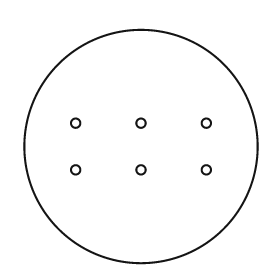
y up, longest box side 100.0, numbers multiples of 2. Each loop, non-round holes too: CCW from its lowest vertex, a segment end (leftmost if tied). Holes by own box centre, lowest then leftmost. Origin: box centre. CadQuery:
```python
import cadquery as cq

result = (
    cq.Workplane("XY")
    .moveTo(0.0, 0.0)
    .circle(50.0)
    .moveTo(-28.0, -10.0)
    .circle(2.0)
    .moveTo(0.0, -10.0)
    .circle(2.0)
    .moveTo(28.0, -10.0)
    .circle(2.0)
    .moveTo(-28.0, 10.0)
    .circle(2.0)
    .moveTo(0.0, 10.0)
    .circle(2.0)
    .moveTo(28.0, 10.0)
    .circle(2.0)
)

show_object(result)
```